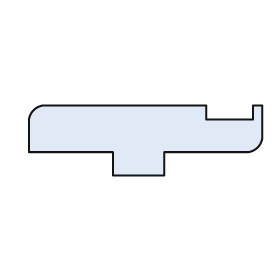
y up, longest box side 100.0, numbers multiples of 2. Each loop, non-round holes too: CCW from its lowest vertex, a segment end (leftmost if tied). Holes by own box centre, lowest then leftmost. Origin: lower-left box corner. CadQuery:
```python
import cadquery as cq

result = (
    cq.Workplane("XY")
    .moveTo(36.0, 0.0)
    .lineTo(58.0, 0.0)
    .lineTo(58.0, 10.0)
    .lineTo(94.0, 10.0)
    .threePointArc((98.0, 12.0), (100.0, 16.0))
    .lineTo(100.0, 30.0)
    .lineTo(96.0, 30.0)
    .lineTo(96.0, 24.0)
    .lineTo(76.0, 24.0)
    .lineTo(76.0, 30.0)
    .lineTo(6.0, 30.0)
    .threePointArc((2.0, 28.0), (0.0, 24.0))
    .lineTo(0.0, 10.0)
    .lineTo(36.0, 10.0)
    .close()
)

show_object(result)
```